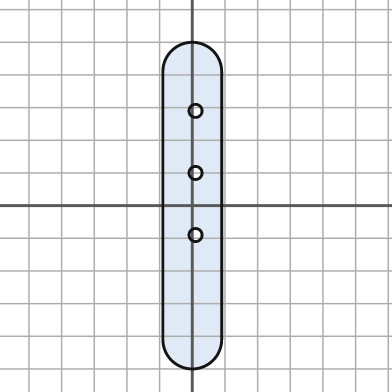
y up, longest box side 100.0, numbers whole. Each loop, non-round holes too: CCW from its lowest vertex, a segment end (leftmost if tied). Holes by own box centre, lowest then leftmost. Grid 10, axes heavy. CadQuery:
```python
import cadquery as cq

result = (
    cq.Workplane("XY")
    .moveTo(-9.0, -41.0)
    .threePointArc((0.0, -50.0), (9.0, -41.0))
    .lineTo(9.0, 41.0)
    .threePointArc((0.0, 50.0), (-9.0, 41.0))
    .close()
    .moveTo(1.0, -9.0)
    .circle(2.0)
    .moveTo(1.0, 10.0)
    .circle(2.0)
    .moveTo(1.0, 29.0)
    .circle(2.0)
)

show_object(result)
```